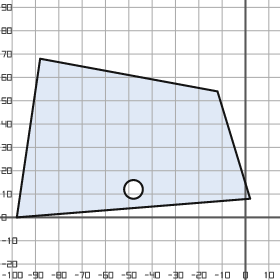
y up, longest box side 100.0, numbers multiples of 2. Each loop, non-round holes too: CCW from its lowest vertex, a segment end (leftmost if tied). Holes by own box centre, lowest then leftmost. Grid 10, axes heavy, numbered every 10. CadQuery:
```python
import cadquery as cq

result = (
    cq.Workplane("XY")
    .moveTo(-98.0, 0.0)
    .lineTo(2.0, 8.0)
    .lineTo(-12.0, 54.0)
    .lineTo(-88.0, 68.0)
    .close()
    .moveTo(-48.0, 12.0)
    .circle(4.0)
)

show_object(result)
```